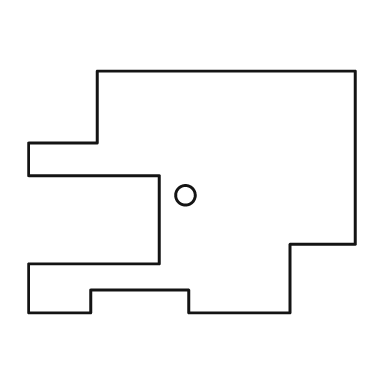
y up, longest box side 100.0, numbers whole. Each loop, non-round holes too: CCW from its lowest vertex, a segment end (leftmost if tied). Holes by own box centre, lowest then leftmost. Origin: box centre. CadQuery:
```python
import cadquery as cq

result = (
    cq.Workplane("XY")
    .moveTo(-50.0, -37.0)
    .lineTo(-31.0, -37.0)
    .lineTo(-31.0, -30.0)
    .lineTo(-1.0, -30.0)
    .lineTo(-1.0, -37.0)
    .lineTo(30.0, -37.0)
    .lineTo(30.0, -16.0)
    .lineTo(50.0, -16.0)
    .lineTo(50.0, 37.0)
    .lineTo(-29.0, 37.0)
    .lineTo(-29.0, 15.0)
    .lineTo(-50.0, 15.0)
    .lineTo(-50.0, 5.0)
    .lineTo(-10.0, 5.0)
    .lineTo(-10.0, -22.0)
    .lineTo(-50.0, -22.0)
    .close()
    .moveTo(-2.0, -1.0)
    .circle(3.0)
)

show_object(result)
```